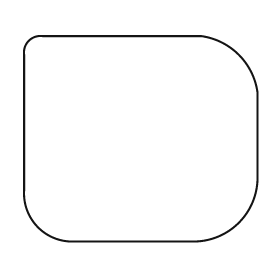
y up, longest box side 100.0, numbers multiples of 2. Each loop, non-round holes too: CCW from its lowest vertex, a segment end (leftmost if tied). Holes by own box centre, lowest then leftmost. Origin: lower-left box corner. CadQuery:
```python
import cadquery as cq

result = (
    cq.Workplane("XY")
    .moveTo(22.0, 0.0)
    .lineTo(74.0, 0.0)
    .threePointArc((92.0, 8.0), (100.0, 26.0))
    .lineTo(100.0, 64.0)
    .threePointArc((92.0, 80.0), (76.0, 88.0))
    .lineTo(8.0, 88.0)
    .threePointArc((2.0, 86.0), (0.0, 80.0))
    .lineTo(0.0, 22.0)
    .threePointArc((6.0, 6.0), (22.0, 0.0))
    .close()
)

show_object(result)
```